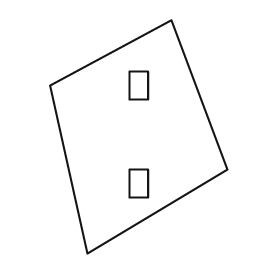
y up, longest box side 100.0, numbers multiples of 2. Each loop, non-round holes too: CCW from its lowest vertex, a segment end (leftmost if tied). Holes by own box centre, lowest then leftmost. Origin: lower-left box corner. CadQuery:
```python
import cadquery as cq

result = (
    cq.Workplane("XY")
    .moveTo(16.0, 0.0)
    .lineTo(76.0, 36.0)
    .lineTo(52.0, 100.0)
    .lineTo(0.0, 72.0)
    .close()
    .moveTo(34.0, 24.0)
    .lineTo(42.0, 24.0)
    .lineTo(42.0, 36.0)
    .lineTo(34.0, 36.0)
    .close()
    .moveTo(34.0, 66.0)
    .lineTo(42.0, 66.0)
    .lineTo(42.0, 78.0)
    .lineTo(34.0, 78.0)
    .close()
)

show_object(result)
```